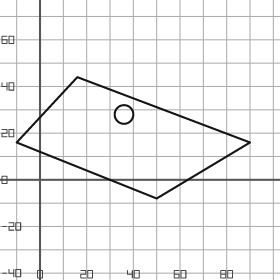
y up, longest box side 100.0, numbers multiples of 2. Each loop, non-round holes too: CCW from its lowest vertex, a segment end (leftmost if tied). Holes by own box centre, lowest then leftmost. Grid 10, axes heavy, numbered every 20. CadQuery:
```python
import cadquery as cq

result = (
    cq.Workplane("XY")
    .moveTo(50.0, -8.0)
    .lineTo(90.0, 16.0)
    .lineTo(16.0, 44.0)
    .lineTo(-10.0, 16.0)
    .close()
    .moveTo(36.0, 28.0)
    .circle(4.0)
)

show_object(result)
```